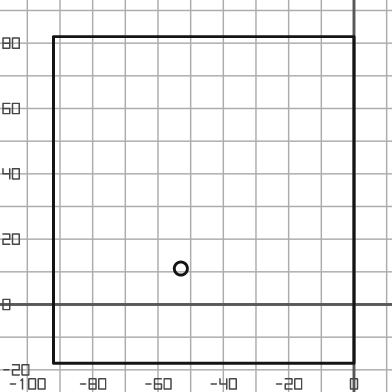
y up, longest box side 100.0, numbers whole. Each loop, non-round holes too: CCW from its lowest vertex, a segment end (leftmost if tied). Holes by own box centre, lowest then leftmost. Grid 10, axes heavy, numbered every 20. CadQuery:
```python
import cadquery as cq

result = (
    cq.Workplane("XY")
    .moveTo(-92.0, -18.0)
    .lineTo(0.0, -18.0)
    .lineTo(0.0, 82.0)
    .lineTo(-92.0, 82.0)
    .close()
    .moveTo(-53.0, 11.0)
    .circle(2.0)
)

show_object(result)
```